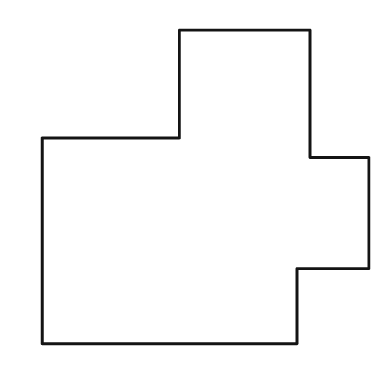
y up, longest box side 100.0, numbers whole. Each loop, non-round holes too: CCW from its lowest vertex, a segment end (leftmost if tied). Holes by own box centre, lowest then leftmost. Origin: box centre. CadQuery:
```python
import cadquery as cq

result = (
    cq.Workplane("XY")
    .moveTo(-50.0, -48.0)
    .lineTo(28.0, -48.0)
    .lineTo(28.0, -25.0)
    .lineTo(50.0, -25.0)
    .lineTo(50.0, 9.0)
    .lineTo(32.0, 9.0)
    .lineTo(32.0, 48.0)
    .lineTo(-8.0, 48.0)
    .lineTo(-8.0, 15.0)
    .lineTo(-50.0, 15.0)
    .close()
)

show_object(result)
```